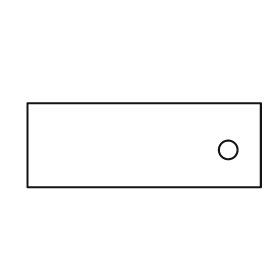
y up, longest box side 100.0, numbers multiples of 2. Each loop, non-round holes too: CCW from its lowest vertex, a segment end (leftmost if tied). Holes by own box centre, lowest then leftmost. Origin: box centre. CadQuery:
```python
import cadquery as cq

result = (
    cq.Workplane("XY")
    .moveTo(-50.0, -18.0)
    .lineTo(50.0, -18.0)
    .lineTo(50.0, 18.0)
    .lineTo(-50.0, 18.0)
    .close()
    .moveTo(36.0, -2.0)
    .circle(4.0)
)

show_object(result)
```